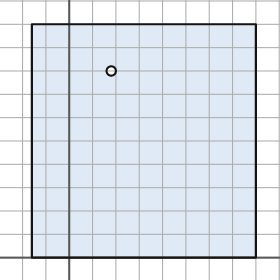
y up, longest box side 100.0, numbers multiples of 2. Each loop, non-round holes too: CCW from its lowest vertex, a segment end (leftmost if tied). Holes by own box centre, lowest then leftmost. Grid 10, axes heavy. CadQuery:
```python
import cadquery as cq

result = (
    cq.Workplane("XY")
    .moveTo(-16.0, 0.0)
    .lineTo(80.0, 0.0)
    .lineTo(80.0, 100.0)
    .lineTo(-16.0, 100.0)
    .close()
    .moveTo(18.0, 80.0)
    .circle(2.0)
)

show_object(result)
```